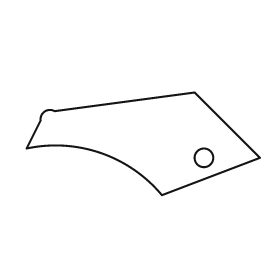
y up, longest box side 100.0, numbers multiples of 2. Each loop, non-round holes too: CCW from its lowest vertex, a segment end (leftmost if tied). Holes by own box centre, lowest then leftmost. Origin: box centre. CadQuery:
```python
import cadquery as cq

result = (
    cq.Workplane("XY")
    .moveTo(8.0, -22.0)
    .lineTo(50.0, -6.0)
    .lineTo(22.0, 22.0)
    .lineTo(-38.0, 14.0)
    .threePointArc((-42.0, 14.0), (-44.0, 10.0))
    .lineTo(-50.0, -2.0)
    .threePointArc((-18.0, -4.0), (8.0, -22.0))
    .close()
    .moveTo(26.0, -6.0)
    .circle(4.0)
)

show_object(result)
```